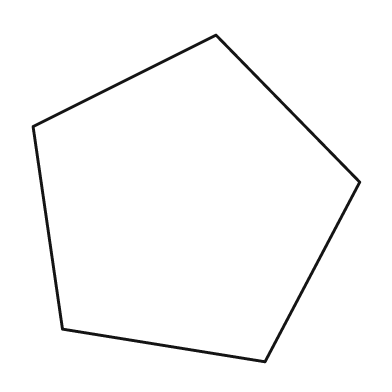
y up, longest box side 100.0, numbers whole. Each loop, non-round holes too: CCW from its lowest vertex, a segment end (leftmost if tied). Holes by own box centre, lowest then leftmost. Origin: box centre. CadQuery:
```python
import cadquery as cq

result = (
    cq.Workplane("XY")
    .moveTo(21.0, -50.0)
    .lineTo(50.0, 5.0)
    .lineTo(6.0, 50.0)
    .lineTo(-50.0, 22.0)
    .lineTo(-41.0, -40.0)
    .close()
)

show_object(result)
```